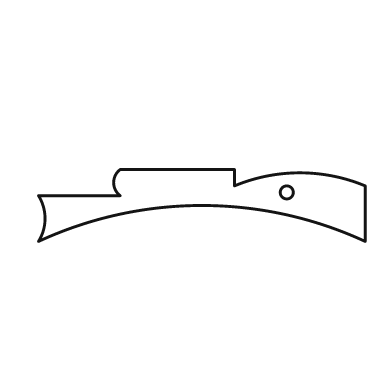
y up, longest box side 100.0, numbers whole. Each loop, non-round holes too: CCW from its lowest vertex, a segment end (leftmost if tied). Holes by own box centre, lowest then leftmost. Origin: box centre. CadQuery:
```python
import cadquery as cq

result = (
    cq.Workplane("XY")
    .moveTo(-50.0, -11.0)
    .threePointArc((0.0, 0.0), (50.0, -11.0))
    .lineTo(50.0, 6.0)
    .threePointArc((30.0, 10.0), (10.0, 6.0))
    .lineTo(10.0, 11.0)
    .lineTo(-25.0, 11.0)
    .threePointArc((-27.0, 7.0), (-25.0, 3.0))
    .lineTo(-50.0, 3.0)
    .threePointArc((-48.0, -4.0), (-50.0, -11.0))
    .close()
    .moveTo(26.0, 4.0)
    .circle(2.0)
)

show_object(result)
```